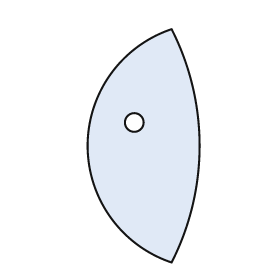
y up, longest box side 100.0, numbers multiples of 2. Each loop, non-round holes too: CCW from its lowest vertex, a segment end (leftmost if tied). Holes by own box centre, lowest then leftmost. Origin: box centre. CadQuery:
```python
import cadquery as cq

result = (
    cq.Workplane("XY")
    .moveTo(12.0, -50.0)
    .threePointArc((24.0, 0.0), (12.0, 50.0))
    .threePointArc((-24.0, 0.0), (12.0, -50.0))
    .close()
    .moveTo(-4.0, 10.0)
    .circle(4.0)
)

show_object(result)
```